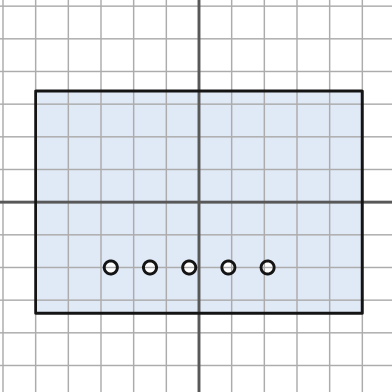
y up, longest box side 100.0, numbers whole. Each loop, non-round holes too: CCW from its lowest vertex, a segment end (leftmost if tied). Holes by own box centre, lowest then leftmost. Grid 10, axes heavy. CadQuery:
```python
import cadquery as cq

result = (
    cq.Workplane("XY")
    .moveTo(-50.0, -34.0)
    .lineTo(50.0, -34.0)
    .lineTo(50.0, 34.0)
    .lineTo(-50.0, 34.0)
    .close()
    .moveTo(-27.0, -20.0)
    .circle(2.0)
    .moveTo(-15.0, -20.0)
    .circle(2.0)
    .moveTo(-3.0, -20.0)
    .circle(2.0)
    .moveTo(9.0, -20.0)
    .circle(2.0)
    .moveTo(21.0, -20.0)
    .circle(2.0)
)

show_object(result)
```